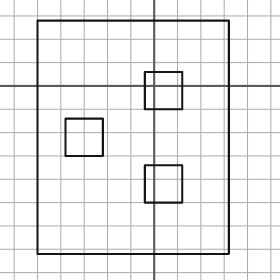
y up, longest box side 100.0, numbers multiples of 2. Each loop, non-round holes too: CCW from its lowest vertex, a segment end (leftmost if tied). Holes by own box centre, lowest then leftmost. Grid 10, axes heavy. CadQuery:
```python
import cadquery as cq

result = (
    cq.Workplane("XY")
    .moveTo(-50.0, -72.0)
    .lineTo(32.0, -72.0)
    .lineTo(32.0, 28.0)
    .lineTo(-50.0, 28.0)
    .close()
    .moveTo(-4.0, -50.0)
    .lineTo(12.0, -50.0)
    .lineTo(12.0, -34.0)
    .lineTo(-4.0, -34.0)
    .close()
    .moveTo(-38.0, -30.0)
    .lineTo(-22.0, -30.0)
    .lineTo(-22.0, -14.0)
    .lineTo(-38.0, -14.0)
    .close()
    .moveTo(-4.0, -10.0)
    .lineTo(12.0, -10.0)
    .lineTo(12.0, 6.0)
    .lineTo(-4.0, 6.0)
    .close()
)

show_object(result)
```